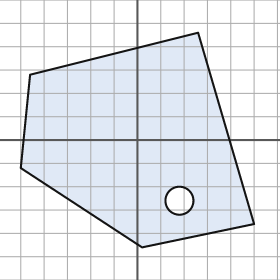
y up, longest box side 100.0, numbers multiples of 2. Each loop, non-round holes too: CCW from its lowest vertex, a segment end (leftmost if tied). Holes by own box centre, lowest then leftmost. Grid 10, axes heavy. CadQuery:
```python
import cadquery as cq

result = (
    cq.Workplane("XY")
    .moveTo(2.0, -46.0)
    .lineTo(50.0, -36.0)
    .lineTo(26.0, 46.0)
    .lineTo(-46.0, 28.0)
    .lineTo(-50.0, -12.0)
    .close()
    .moveTo(18.0, -26.0)
    .circle(6.0)
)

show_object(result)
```